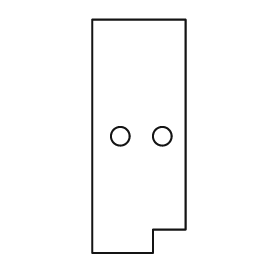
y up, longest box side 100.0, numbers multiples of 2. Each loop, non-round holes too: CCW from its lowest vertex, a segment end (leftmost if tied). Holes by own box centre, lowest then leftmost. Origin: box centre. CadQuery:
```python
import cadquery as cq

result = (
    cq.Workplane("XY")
    .moveTo(-20.0, -50.0)
    .lineTo(6.0, -50.0)
    .lineTo(6.0, -40.0)
    .lineTo(20.0, -40.0)
    .lineTo(20.0, 50.0)
    .lineTo(-20.0, 50.0)
    .close()
    .moveTo(-8.0, 0.0)
    .circle(4.0)
    .moveTo(10.0, 0.0)
    .circle(4.0)
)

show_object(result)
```